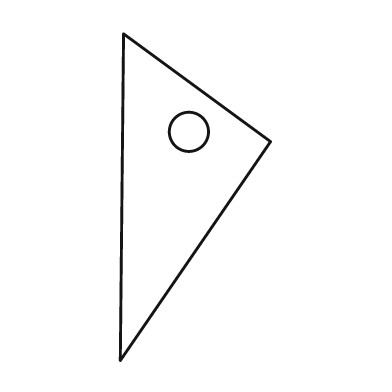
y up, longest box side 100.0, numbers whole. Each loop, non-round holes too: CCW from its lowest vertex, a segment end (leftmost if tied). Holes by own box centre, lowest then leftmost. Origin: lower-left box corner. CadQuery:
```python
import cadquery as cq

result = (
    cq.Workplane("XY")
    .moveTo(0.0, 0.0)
    .lineTo(46.0, 67.0)
    .lineTo(1.0, 100.0)
    .close()
    .moveTo(21.0, 70.0)
    .circle(6.0)
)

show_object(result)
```